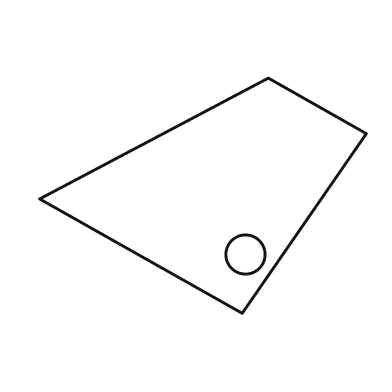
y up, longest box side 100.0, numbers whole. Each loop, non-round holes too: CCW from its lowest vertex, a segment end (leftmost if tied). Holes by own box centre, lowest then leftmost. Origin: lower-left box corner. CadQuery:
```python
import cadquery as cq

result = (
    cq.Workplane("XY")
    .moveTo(62.0, 0.0)
    .lineTo(100.0, 55.0)
    .lineTo(70.0, 72.0)
    .lineTo(0.0, 35.0)
    .close()
    .moveTo(63.0, 18.0)
    .circle(6.0)
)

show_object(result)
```